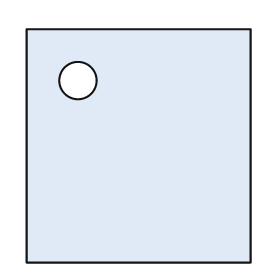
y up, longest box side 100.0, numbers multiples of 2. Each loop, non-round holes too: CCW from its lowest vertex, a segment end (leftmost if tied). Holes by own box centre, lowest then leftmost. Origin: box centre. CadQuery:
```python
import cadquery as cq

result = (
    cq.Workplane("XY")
    .moveTo(-48.0, -50.0)
    .lineTo(48.0, -50.0)
    .lineTo(48.0, 50.0)
    .lineTo(-48.0, 50.0)
    .close()
    .moveTo(-26.0, 28.0)
    .circle(8.0)
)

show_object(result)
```